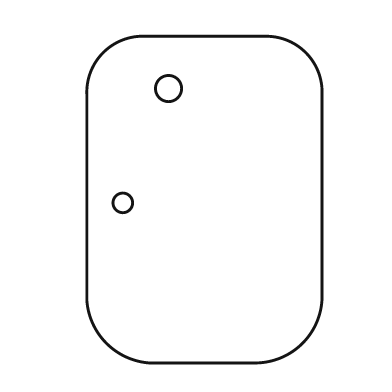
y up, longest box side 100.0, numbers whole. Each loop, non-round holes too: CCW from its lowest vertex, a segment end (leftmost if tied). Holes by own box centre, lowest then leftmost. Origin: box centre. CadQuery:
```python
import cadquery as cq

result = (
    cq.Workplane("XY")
    .moveTo(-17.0, -50.0)
    .lineTo(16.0, -50.0)
    .threePointArc((30.0, -44.0), (36.0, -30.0))
    .lineTo(36.0, 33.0)
    .threePointArc((31.0, 45.0), (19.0, 50.0))
    .lineTo(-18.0, 50.0)
    .threePointArc((-31.0, 45.0), (-36.0, 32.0))
    .lineTo(-36.0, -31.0)
    .threePointArc((-30.0, -44.0), (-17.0, -50.0))
    .close()
    .moveTo(-25.0, -1.0)
    .circle(3.0)
    .moveTo(-11.0, 34.0)
    .circle(4.0)
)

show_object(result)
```